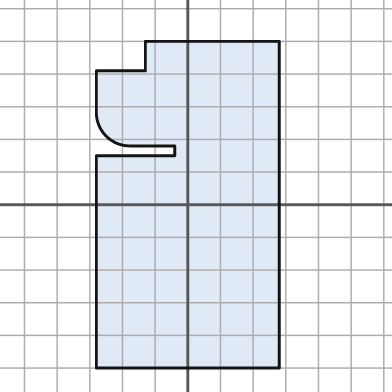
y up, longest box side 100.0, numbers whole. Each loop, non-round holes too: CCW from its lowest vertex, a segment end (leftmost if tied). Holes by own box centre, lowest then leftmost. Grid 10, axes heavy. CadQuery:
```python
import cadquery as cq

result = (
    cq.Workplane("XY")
    .moveTo(-28.0, -50.0)
    .lineTo(28.0, -50.0)
    .lineTo(28.0, 50.0)
    .lineTo(-13.0, 50.0)
    .lineTo(-13.0, 41.0)
    .lineTo(-28.0, 41.0)
    .lineTo(-28.0, 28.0)
    .threePointArc((-25.0, 21.0), (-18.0, 18.0))
    .lineTo(-4.0, 18.0)
    .lineTo(-4.0, 15.0)
    .lineTo(-28.0, 15.0)
    .close()
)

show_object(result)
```